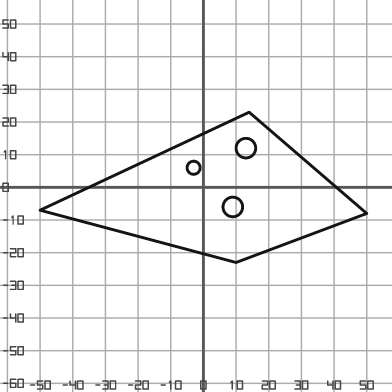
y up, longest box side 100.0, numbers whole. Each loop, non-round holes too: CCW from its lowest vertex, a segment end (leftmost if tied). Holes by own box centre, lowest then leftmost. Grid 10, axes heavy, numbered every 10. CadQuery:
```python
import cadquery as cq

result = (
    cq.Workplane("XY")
    .moveTo(10.0, -23.0)
    .lineTo(50.0, -8.0)
    .lineTo(14.0, 23.0)
    .lineTo(-50.0, -7.0)
    .close()
    .moveTo(9.0, -6.0)
    .circle(3.0)
    .moveTo(-3.0, 6.0)
    .circle(2.0)
    .moveTo(13.0, 12.0)
    .circle(3.0)
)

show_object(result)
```